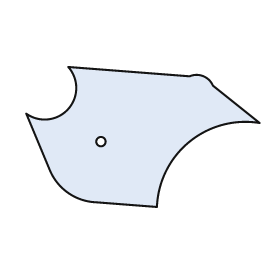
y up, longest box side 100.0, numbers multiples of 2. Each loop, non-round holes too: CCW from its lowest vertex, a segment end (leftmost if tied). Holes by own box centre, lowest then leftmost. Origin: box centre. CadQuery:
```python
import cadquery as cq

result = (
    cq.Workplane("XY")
    .moveTo(6.0, -30.0)
    .threePointArc((20.0, -2.0), (50.0, 6.0))
    .lineTo(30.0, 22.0)
    .threePointArc((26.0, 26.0), (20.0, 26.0))
    .lineTo(-32.0, 30.0)
    .threePointArc((-32.0, 12.0), (-50.0, 10.0))
    .lineTo(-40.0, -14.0)
    .threePointArc((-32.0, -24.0), (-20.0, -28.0))
    .close()
    .moveTo(-18.0, -2.0)
    .circle(2.0)
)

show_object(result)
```